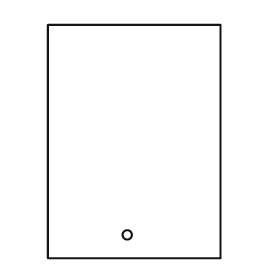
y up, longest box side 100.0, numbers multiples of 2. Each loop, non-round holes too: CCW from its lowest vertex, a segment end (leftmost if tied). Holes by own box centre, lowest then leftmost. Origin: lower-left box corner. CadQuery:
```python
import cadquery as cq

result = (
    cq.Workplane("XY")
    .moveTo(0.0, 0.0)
    .lineTo(74.0, 0.0)
    .lineTo(74.0, 100.0)
    .lineTo(0.0, 100.0)
    .close()
    .moveTo(34.0, 10.0)
    .circle(2.0)
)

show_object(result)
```